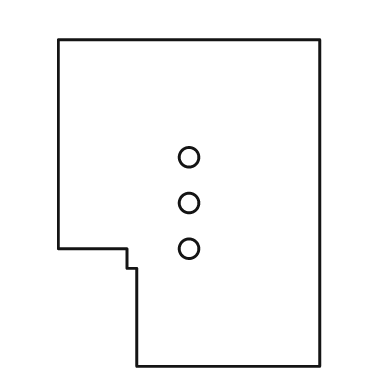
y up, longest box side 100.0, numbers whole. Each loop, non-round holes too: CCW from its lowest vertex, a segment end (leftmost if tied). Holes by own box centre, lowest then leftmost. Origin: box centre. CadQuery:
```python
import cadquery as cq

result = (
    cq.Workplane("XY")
    .moveTo(-16.0, -50.0)
    .lineTo(40.0, -50.0)
    .lineTo(40.0, 50.0)
    .lineTo(-40.0, 50.0)
    .lineTo(-40.0, -14.0)
    .lineTo(-19.0, -14.0)
    .lineTo(-19.0, -20.0)
    .lineTo(-16.0, -20.0)
    .close()
    .moveTo(0.0, -14.0)
    .circle(3.0)
    .moveTo(0.0, 0.0)
    .circle(3.0)
    .moveTo(0.0, 14.0)
    .circle(3.0)
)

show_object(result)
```